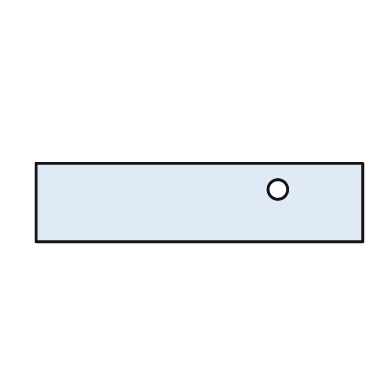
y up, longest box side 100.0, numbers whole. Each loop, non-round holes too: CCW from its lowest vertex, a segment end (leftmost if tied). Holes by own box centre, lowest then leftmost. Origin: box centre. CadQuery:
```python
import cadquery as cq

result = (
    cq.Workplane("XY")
    .moveTo(-50.0, -12.0)
    .lineTo(50.0, -12.0)
    .lineTo(50.0, 12.0)
    .lineTo(-50.0, 12.0)
    .close()
    .moveTo(24.0, 4.0)
    .circle(3.0)
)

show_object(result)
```